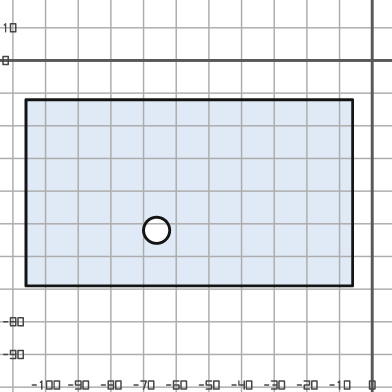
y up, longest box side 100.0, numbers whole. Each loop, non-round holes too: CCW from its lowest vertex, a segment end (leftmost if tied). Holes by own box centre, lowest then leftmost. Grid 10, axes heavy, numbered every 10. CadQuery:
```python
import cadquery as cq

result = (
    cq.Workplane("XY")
    .moveTo(-106.0, -69.0)
    .lineTo(-6.0, -69.0)
    .lineTo(-6.0, -12.0)
    .lineTo(-106.0, -12.0)
    .close()
    .moveTo(-66.0, -52.0)
    .circle(4.0)
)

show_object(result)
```